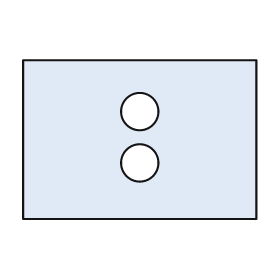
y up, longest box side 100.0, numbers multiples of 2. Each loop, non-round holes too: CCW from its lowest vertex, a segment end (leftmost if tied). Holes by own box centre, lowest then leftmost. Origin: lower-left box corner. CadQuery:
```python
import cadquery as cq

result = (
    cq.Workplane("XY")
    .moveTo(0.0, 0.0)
    .lineTo(100.0, 0.0)
    .lineTo(100.0, 68.0)
    .lineTo(0.0, 68.0)
    .close()
    .moveTo(50.0, 24.0)
    .circle(8.0)
    .moveTo(50.0, 46.0)
    .circle(8.0)
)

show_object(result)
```